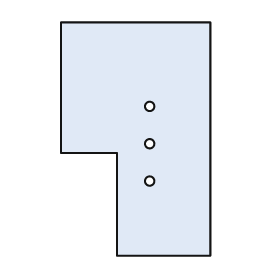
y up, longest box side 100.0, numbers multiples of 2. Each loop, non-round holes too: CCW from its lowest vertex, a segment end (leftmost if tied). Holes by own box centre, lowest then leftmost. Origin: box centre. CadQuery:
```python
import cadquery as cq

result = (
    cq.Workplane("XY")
    .moveTo(-8.0, -50.0)
    .lineTo(32.0, -50.0)
    .lineTo(32.0, 50.0)
    .lineTo(-32.0, 50.0)
    .lineTo(-32.0, -6.0)
    .lineTo(-8.0, -6.0)
    .close()
    .moveTo(6.0, -18.0)
    .circle(2.0)
    .moveTo(6.0, -2.0)
    .circle(2.0)
    .moveTo(6.0, 14.0)
    .circle(2.0)
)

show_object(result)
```